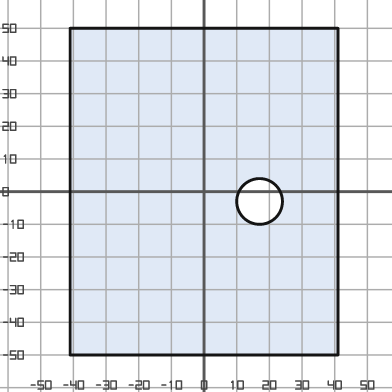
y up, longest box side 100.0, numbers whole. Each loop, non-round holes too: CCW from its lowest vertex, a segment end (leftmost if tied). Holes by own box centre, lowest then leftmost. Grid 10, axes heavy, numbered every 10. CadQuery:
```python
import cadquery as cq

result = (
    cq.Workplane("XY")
    .moveTo(-41.0, -50.0)
    .lineTo(41.0, -50.0)
    .lineTo(41.0, 50.0)
    .lineTo(-41.0, 50.0)
    .close()
    .moveTo(17.0, -3.0)
    .circle(7.0)
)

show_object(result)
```